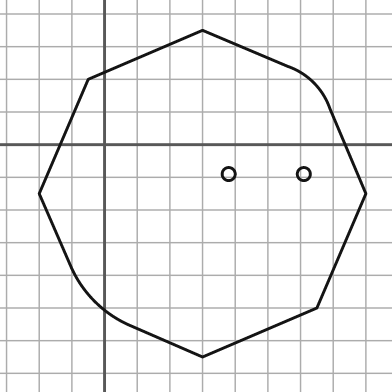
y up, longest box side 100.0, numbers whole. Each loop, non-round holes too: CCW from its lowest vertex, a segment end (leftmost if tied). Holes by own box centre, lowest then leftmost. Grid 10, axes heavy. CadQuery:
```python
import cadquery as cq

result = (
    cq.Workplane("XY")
    .moveTo(30.0, -65.0)
    .lineTo(65.0, -50.0)
    .lineTo(80.0, -15.0)
    .lineTo(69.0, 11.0)
    .threePointArc((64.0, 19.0), (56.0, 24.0))
    .lineTo(30.0, 35.0)
    .lineTo(-5.0, 20.0)
    .lineTo(-20.0, -15.0)
    .lineTo(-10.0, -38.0)
    .threePointArc((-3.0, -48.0), (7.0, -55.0))
    .close()
    .moveTo(38.0, -9.0)
    .circle(2.0)
    .moveTo(61.0, -9.0)
    .circle(2.0)
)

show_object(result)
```